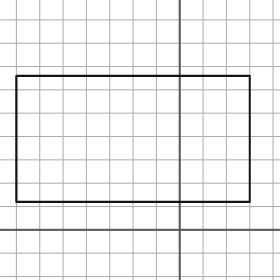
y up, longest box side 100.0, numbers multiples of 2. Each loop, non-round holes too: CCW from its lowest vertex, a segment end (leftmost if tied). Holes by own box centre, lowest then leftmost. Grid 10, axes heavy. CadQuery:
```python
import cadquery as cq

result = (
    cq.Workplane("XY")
    .moveTo(-70.0, 12.0)
    .lineTo(30.0, 12.0)
    .lineTo(30.0, 66.0)
    .lineTo(-70.0, 66.0)
    .close()
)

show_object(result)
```